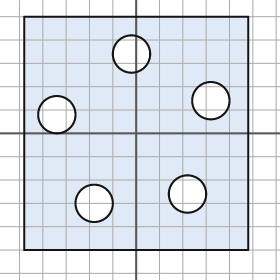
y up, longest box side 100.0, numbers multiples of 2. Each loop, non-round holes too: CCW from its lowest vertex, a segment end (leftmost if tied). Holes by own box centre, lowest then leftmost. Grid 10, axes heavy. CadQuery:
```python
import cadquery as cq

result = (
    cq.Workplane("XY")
    .moveTo(-48.0, -50.0)
    .lineTo(48.0, -50.0)
    .lineTo(48.0, 50.0)
    .lineTo(-48.0, 50.0)
    .close()
    .moveTo(-18.0, -30.0)
    .circle(8.0)
    .moveTo(22.0, -26.0)
    .circle(8.0)
    .moveTo(-34.0, 8.0)
    .circle(8.0)
    .moveTo(32.0, 14.0)
    .circle(8.0)
    .moveTo(-2.0, 34.0)
    .circle(8.0)
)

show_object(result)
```